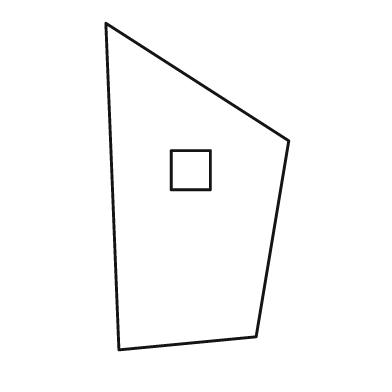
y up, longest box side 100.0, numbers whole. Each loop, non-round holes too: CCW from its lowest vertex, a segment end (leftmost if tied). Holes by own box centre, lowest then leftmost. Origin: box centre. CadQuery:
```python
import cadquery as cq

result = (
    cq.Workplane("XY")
    .moveTo(-24.0, -50.0)
    .lineTo(18.0, -46.0)
    .lineTo(28.0, 14.0)
    .lineTo(-28.0, 50.0)
    .close()
    .moveTo(-8.0, -1.0)
    .lineTo(4.0, -1.0)
    .lineTo(4.0, 11.0)
    .lineTo(-8.0, 11.0)
    .close()
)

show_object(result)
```